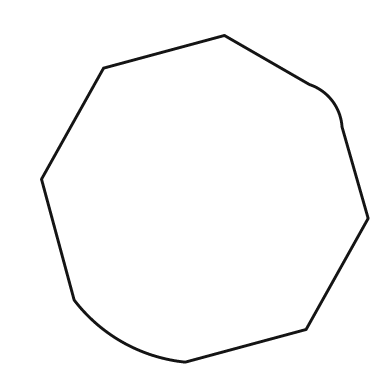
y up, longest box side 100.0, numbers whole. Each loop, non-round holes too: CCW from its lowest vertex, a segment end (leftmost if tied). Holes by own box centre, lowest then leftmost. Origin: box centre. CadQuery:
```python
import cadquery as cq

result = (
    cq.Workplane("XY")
    .moveTo(-6.0, -50.0)
    .lineTo(31.0, -40.0)
    .lineTo(50.0, -6.0)
    .lineTo(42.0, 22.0)
    .threePointArc((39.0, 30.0), (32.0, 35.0))
    .lineTo(6.0, 50.0)
    .lineTo(-31.0, 40.0)
    .lineTo(-50.0, 6.0)
    .lineTo(-40.0, -31.0)
    .threePointArc((-25.0, -44.0), (-6.0, -50.0))
    .close()
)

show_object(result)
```